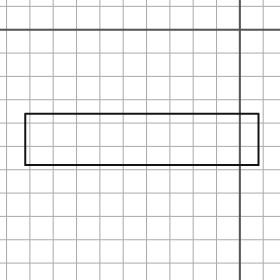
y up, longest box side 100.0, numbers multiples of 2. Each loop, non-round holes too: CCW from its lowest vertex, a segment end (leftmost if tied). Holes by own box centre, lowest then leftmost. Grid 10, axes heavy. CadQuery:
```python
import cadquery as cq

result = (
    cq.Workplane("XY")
    .moveTo(-92.0, -58.0)
    .lineTo(8.0, -58.0)
    .lineTo(8.0, -36.0)
    .lineTo(-92.0, -36.0)
    .close()
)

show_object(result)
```